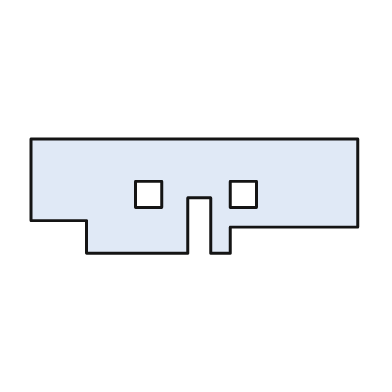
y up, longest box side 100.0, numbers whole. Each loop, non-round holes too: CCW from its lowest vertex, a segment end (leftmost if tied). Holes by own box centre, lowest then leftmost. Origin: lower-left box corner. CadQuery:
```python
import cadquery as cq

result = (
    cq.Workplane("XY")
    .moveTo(17.0, 0.0)
    .lineTo(48.0, 0.0)
    .lineTo(48.0, 17.0)
    .lineTo(55.0, 17.0)
    .lineTo(55.0, 0.0)
    .lineTo(61.0, 0.0)
    .lineTo(61.0, 8.0)
    .lineTo(100.0, 8.0)
    .lineTo(100.0, 35.0)
    .lineTo(0.0, 35.0)
    .lineTo(0.0, 10.0)
    .lineTo(17.0, 10.0)
    .close()
    .moveTo(32.0, 14.0)
    .lineTo(40.0, 14.0)
    .lineTo(40.0, 22.0)
    .lineTo(32.0, 22.0)
    .close()
    .moveTo(61.0, 14.0)
    .lineTo(69.0, 14.0)
    .lineTo(69.0, 22.0)
    .lineTo(61.0, 22.0)
    .close()
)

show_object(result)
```